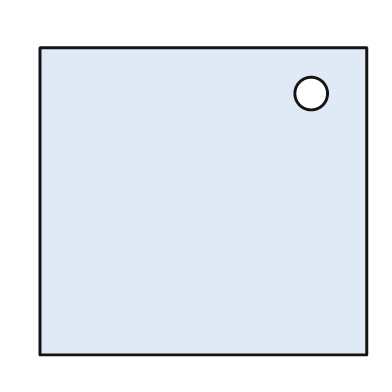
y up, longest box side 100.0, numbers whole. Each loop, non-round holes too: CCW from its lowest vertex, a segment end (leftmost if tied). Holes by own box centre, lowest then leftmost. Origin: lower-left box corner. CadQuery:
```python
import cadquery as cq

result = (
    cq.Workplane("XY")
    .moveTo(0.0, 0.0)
    .lineTo(100.0, 0.0)
    .lineTo(100.0, 94.0)
    .lineTo(0.0, 94.0)
    .close()
    .moveTo(83.0, 80.0)
    .circle(5.0)
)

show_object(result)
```